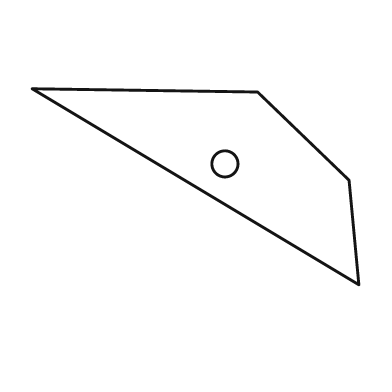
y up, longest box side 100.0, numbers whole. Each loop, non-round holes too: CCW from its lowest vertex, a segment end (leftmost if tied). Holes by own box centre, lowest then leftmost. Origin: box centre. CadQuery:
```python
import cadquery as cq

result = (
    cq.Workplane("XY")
    .moveTo(50.0, -30.0)
    .lineTo(47.0, 2.0)
    .lineTo(19.0, 29.0)
    .lineTo(-50.0, 30.0)
    .close()
    .moveTo(9.0, 7.0)
    .circle(4.0)
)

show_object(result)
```